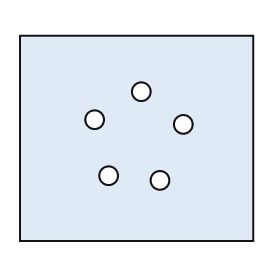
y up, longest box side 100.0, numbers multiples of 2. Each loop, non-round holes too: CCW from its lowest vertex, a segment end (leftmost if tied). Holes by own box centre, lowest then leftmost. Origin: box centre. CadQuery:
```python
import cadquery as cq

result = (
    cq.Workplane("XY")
    .moveTo(-50.0, -44.0)
    .lineTo(50.0, -44.0)
    .lineTo(50.0, 44.0)
    .lineTo(-50.0, 44.0)
    .close()
    .moveTo(10.0, -18.0)
    .circle(4.0)
    .moveTo(-12.0, -16.0)
    .circle(4.0)
    .moveTo(20.0, 6.0)
    .circle(4.0)
    .moveTo(-18.0, 8.0)
    .circle(4.0)
    .moveTo(2.0, 20.0)
    .circle(4.0)
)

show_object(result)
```